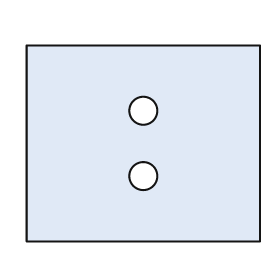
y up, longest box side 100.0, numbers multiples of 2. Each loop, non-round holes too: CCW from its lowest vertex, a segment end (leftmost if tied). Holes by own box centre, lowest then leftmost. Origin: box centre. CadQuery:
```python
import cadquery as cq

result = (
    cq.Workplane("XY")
    .moveTo(-50.0, -42.0)
    .lineTo(50.0, -42.0)
    .lineTo(50.0, 42.0)
    .lineTo(-50.0, 42.0)
    .close()
    .moveTo(0.0, -14.0)
    .circle(6.0)
    .moveTo(0.0, 14.0)
    .circle(6.0)
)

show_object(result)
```